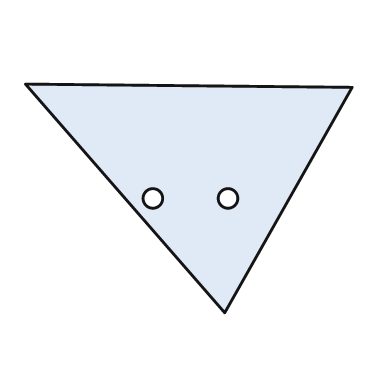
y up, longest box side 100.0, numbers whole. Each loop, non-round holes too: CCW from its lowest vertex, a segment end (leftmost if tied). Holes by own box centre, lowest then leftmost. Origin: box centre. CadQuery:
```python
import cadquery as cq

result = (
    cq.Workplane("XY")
    .moveTo(11.0, -35.0)
    .lineTo(50.0, 34.0)
    .lineTo(-50.0, 35.0)
    .close()
    .moveTo(-11.0, 0.0)
    .circle(3.0)
    .moveTo(12.0, 0.0)
    .circle(3.0)
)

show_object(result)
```